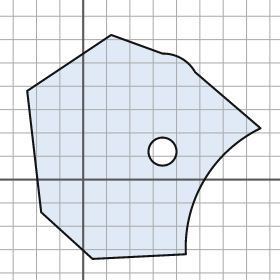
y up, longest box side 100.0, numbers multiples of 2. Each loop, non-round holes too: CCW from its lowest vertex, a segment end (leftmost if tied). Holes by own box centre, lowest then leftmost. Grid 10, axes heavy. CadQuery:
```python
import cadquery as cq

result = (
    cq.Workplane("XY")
    .moveTo(4.0, -34.0)
    .lineTo(44.0, -32.0)
    .threePointArc((52.0, 0.0), (76.0, 22.0))
    .lineTo(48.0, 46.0)
    .threePointArc((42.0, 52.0), (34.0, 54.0))
    .lineTo(12.0, 62.0)
    .lineTo(-24.0, 38.0)
    .lineTo(-18.0, -14.0)
    .close()
    .moveTo(34.0, 12.0)
    .circle(6.0)
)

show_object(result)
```